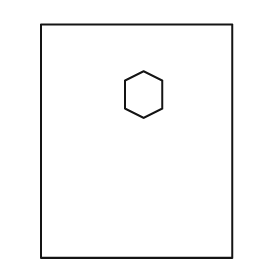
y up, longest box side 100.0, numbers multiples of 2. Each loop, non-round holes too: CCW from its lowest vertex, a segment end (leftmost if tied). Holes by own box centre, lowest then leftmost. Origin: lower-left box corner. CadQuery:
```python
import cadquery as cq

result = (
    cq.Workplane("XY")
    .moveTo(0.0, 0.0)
    .lineTo(82.0, 0.0)
    .lineTo(82.0, 100.0)
    .lineTo(0.0, 100.0)
    .close()
    .moveTo(44.0, 60.0)
    .lineTo(52.0, 64.0)
    .lineTo(52.0, 76.0)
    .lineTo(44.0, 80.0)
    .lineTo(36.0, 76.0)
    .lineTo(36.0, 64.0)
    .close()
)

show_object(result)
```